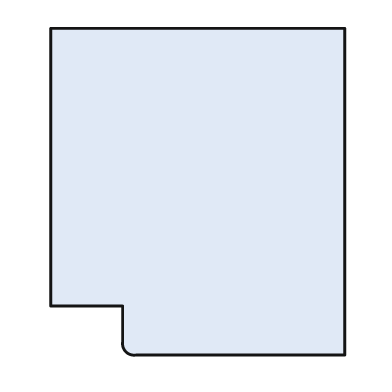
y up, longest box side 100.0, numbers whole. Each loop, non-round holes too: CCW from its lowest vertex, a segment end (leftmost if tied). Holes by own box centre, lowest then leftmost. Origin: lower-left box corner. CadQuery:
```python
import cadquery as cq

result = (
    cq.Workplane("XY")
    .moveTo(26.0, 0.0)
    .lineTo(90.0, 0.0)
    .lineTo(90.0, 100.0)
    .lineTo(0.0, 100.0)
    .lineTo(0.0, 15.0)
    .lineTo(22.0, 15.0)
    .lineTo(22.0, 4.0)
    .threePointArc((23.0, 1.0), (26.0, 0.0))
    .close()
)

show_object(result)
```